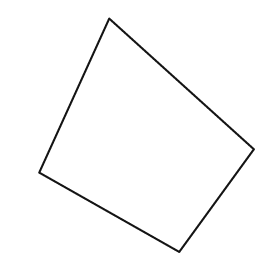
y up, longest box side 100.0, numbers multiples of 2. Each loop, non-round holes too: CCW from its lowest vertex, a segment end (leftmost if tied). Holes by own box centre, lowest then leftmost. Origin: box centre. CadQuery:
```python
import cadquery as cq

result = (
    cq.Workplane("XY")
    .moveTo(14.0, -50.0)
    .lineTo(46.0, -6.0)
    .lineTo(-16.0, 50.0)
    .lineTo(-46.0, -16.0)
    .close()
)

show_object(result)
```